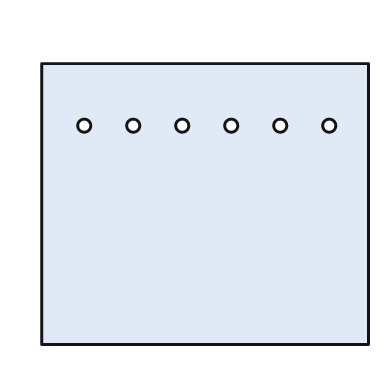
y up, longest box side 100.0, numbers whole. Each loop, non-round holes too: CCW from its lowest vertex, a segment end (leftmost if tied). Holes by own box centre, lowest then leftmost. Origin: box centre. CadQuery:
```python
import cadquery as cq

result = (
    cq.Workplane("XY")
    .moveTo(-50.0, -43.0)
    .lineTo(50.0, -43.0)
    .lineTo(50.0, 43.0)
    .lineTo(-50.0, 43.0)
    .close()
    .moveTo(-37.0, 24.0)
    .circle(2.0)
    .moveTo(-22.0, 24.0)
    .circle(2.0)
    .moveTo(-7.0, 24.0)
    .circle(2.0)
    .moveTo(8.0, 24.0)
    .circle(2.0)
    .moveTo(23.0, 24.0)
    .circle(2.0)
    .moveTo(38.0, 24.0)
    .circle(2.0)
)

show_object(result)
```